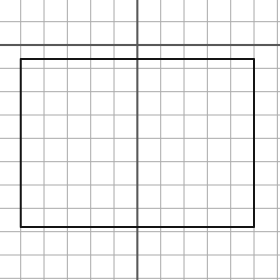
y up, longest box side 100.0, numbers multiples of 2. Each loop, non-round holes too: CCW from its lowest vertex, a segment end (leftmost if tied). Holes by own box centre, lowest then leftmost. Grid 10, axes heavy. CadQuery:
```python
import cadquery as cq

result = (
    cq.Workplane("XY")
    .moveTo(-50.0, -78.0)
    .lineTo(50.0, -78.0)
    .lineTo(50.0, -6.0)
    .lineTo(-50.0, -6.0)
    .close()
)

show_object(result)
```